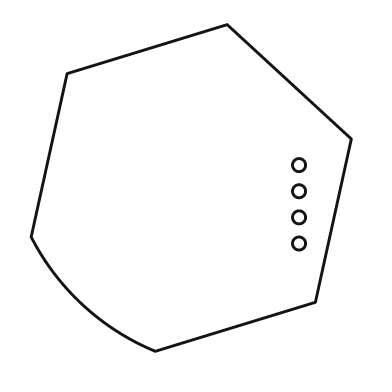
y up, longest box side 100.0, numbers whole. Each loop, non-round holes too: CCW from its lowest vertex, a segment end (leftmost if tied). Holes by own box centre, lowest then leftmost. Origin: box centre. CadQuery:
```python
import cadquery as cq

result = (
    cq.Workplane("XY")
    .moveTo(-11.0, -50.0)
    .lineTo(38.0, -35.0)
    .lineTo(49.0, 15.0)
    .lineTo(11.0, 50.0)
    .lineTo(-38.0, 35.0)
    .lineTo(-49.0, -15.0)
    .threePointArc((-33.0, -36.0), (-11.0, -50.0))
    .close()
    .moveTo(33.0, -17.0)
    .circle(2.0)
    .moveTo(33.0, -9.0)
    .circle(2.0)
    .moveTo(33.0, -1.0)
    .circle(2.0)
    .moveTo(33.0, 7.0)
    .circle(2.0)
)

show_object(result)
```